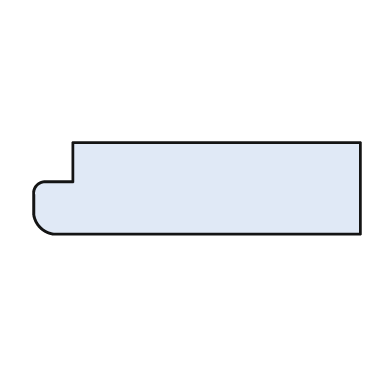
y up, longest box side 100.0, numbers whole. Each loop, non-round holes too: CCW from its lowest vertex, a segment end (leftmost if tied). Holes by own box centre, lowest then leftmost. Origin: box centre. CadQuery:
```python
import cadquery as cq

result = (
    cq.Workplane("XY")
    .moveTo(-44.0, -14.0)
    .lineTo(50.0, -14.0)
    .lineTo(50.0, 14.0)
    .lineTo(-38.0, 14.0)
    .lineTo(-38.0, 2.0)
    .lineTo(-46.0, 2.0)
    .threePointArc((-49.0, 1.0), (-50.0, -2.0))
    .lineTo(-50.0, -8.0)
    .threePointArc((-48.0, -12.0), (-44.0, -14.0))
    .close()
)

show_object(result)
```